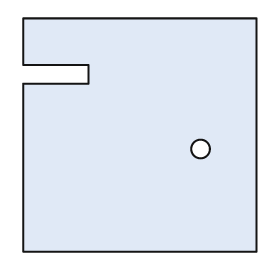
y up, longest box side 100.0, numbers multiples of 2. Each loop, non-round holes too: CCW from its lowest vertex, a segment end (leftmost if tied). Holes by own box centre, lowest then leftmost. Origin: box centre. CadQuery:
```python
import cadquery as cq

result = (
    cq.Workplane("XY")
    .moveTo(-50.0, -50.0)
    .lineTo(50.0, -50.0)
    .lineTo(50.0, 50.0)
    .lineTo(-50.0, 50.0)
    .lineTo(-50.0, 30.0)
    .lineTo(-22.0, 30.0)
    .lineTo(-22.0, 22.0)
    .lineTo(-50.0, 22.0)
    .close()
    .moveTo(26.0, -6.0)
    .circle(4.0)
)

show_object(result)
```